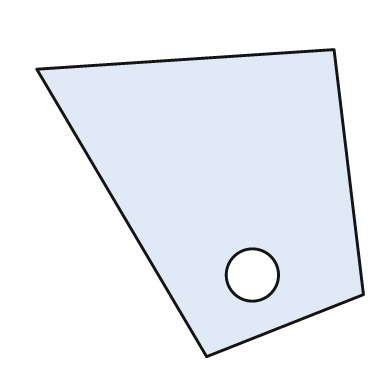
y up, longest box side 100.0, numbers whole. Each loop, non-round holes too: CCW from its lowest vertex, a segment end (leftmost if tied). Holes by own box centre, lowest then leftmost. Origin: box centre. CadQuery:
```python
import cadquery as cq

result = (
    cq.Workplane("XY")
    .moveTo(2.0, -47.0)
    .lineTo(50.0, -28.0)
    .lineTo(41.0, 47.0)
    .lineTo(-50.0, 41.0)
    .close()
    .moveTo(16.0, -22.0)
    .circle(8.0)
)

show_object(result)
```